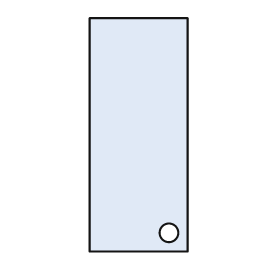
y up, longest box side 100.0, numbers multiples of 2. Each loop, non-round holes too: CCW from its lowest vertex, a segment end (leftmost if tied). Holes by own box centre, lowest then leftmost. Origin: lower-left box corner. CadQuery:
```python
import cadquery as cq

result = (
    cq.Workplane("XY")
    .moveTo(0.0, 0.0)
    .lineTo(42.0, 0.0)
    .lineTo(42.0, 100.0)
    .lineTo(0.0, 100.0)
    .close()
    .moveTo(34.0, 8.0)
    .circle(4.0)
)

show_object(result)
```